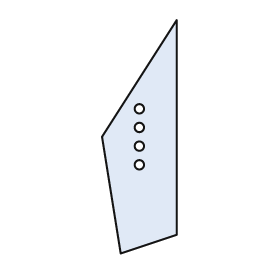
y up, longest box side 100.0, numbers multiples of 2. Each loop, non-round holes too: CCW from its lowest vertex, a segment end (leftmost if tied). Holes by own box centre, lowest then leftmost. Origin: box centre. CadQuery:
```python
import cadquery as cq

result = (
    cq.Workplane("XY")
    .moveTo(-8.0, -50.0)
    .lineTo(16.0, -42.0)
    .lineTo(16.0, 50.0)
    .lineTo(-16.0, 0.0)
    .close()
    .moveTo(0.0, -12.0)
    .circle(2.0)
    .moveTo(0.0, -4.0)
    .circle(2.0)
    .moveTo(0.0, 4.0)
    .circle(2.0)
    .moveTo(0.0, 12.0)
    .circle(2.0)
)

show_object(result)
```